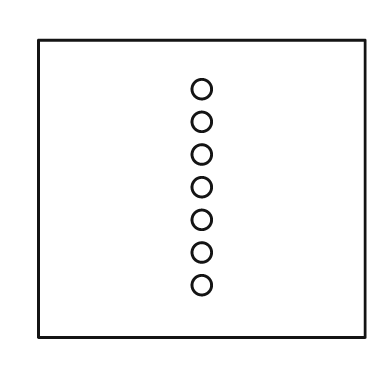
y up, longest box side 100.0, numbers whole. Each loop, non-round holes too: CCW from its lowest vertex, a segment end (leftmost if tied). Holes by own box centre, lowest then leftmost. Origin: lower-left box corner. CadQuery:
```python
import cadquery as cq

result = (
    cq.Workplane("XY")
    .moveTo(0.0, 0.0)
    .lineTo(100.0, 0.0)
    .lineTo(100.0, 91.0)
    .lineTo(0.0, 91.0)
    .close()
    .moveTo(50.0, 16.0)
    .circle(3.0)
    .moveTo(50.0, 26.0)
    .circle(3.0)
    .moveTo(50.0, 36.0)
    .circle(3.0)
    .moveTo(50.0, 46.0)
    .circle(3.0)
    .moveTo(50.0, 56.0)
    .circle(3.0)
    .moveTo(50.0, 66.0)
    .circle(3.0)
    .moveTo(50.0, 76.0)
    .circle(3.0)
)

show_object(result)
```